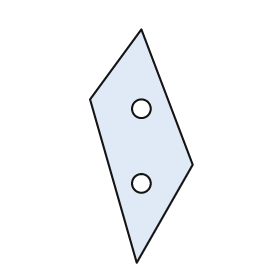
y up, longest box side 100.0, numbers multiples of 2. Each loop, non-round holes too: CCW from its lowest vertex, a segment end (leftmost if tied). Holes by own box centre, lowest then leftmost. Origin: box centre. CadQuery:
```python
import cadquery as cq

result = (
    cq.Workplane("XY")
    .moveTo(-2.0, -50.0)
    .lineTo(22.0, -8.0)
    .lineTo(0.0, 50.0)
    .lineTo(-22.0, 20.0)
    .close()
    .moveTo(0.0, -16.0)
    .circle(4.0)
    .moveTo(0.0, 16.0)
    .circle(4.0)
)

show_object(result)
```